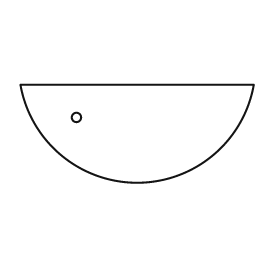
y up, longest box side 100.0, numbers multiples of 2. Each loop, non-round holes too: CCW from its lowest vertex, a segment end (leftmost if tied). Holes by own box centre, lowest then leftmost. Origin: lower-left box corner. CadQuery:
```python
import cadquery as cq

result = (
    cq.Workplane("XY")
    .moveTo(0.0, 42.0)
    .threePointArc((50.0, 0.0), (100.0, 42.0))
    .close()
    .moveTo(24.0, 28.0)
    .circle(2.0)
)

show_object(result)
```